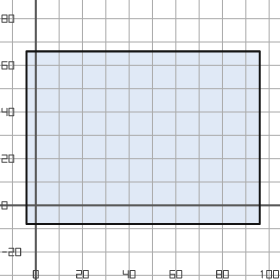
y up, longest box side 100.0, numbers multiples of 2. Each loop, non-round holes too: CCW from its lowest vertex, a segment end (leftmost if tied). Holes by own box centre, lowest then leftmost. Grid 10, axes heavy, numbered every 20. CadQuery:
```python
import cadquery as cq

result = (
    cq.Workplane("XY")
    .moveTo(-4.0, -8.0)
    .lineTo(96.0, -8.0)
    .lineTo(96.0, 66.0)
    .lineTo(-4.0, 66.0)
    .close()
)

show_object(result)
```